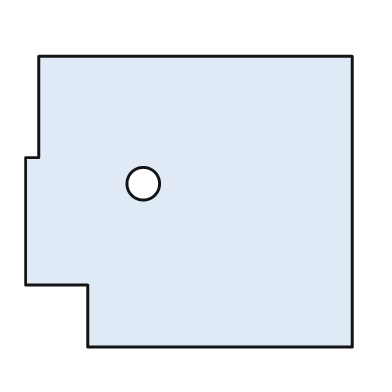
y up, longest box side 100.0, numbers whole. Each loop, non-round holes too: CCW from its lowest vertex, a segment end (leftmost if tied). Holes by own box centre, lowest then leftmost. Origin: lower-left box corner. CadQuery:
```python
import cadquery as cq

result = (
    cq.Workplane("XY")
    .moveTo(19.0, 0.0)
    .lineTo(100.0, 0.0)
    .lineTo(100.0, 89.0)
    .lineTo(4.0, 89.0)
    .lineTo(4.0, 58.0)
    .lineTo(0.0, 58.0)
    .lineTo(0.0, 19.0)
    .lineTo(19.0, 19.0)
    .close()
    .moveTo(36.0, 50.0)
    .circle(5.0)
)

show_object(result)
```